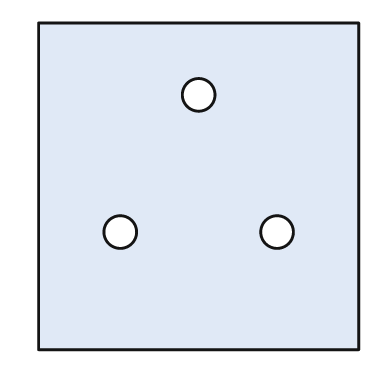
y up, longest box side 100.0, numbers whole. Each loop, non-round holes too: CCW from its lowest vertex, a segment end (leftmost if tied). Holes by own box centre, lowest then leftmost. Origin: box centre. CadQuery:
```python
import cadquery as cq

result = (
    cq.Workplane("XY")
    .moveTo(-49.0, -50.0)
    .lineTo(49.0, -50.0)
    .lineTo(49.0, 50.0)
    .lineTo(-49.0, 50.0)
    .close()
    .moveTo(-24.0, -14.0)
    .circle(5.0)
    .moveTo(24.0, -14.0)
    .circle(5.0)
    .moveTo(0.0, 28.0)
    .circle(5.0)
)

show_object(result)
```